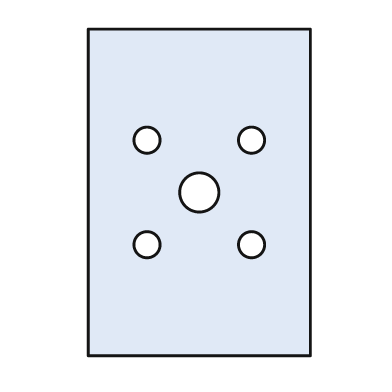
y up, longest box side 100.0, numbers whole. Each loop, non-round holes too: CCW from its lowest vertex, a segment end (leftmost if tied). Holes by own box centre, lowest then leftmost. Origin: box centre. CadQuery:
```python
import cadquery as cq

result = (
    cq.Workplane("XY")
    .moveTo(-34.0, -50.0)
    .lineTo(34.0, -50.0)
    .lineTo(34.0, 50.0)
    .lineTo(-34.0, 50.0)
    .close()
    .moveTo(-16.0, -16.0)
    .circle(4.0)
    .moveTo(16.0, -16.0)
    .circle(4.0)
    .moveTo(0.0, 0.0)
    .circle(6.0)
    .moveTo(-16.0, 16.0)
    .circle(4.0)
    .moveTo(16.0, 16.0)
    .circle(4.0)
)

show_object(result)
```